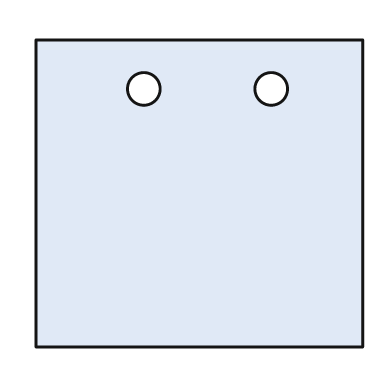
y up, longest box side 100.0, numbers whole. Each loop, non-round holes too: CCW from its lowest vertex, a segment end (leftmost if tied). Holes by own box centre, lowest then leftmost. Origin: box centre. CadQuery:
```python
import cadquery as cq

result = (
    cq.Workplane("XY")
    .moveTo(-50.0, -47.0)
    .lineTo(50.0, -47.0)
    .lineTo(50.0, 47.0)
    .lineTo(-50.0, 47.0)
    .close()
    .moveTo(-17.0, 32.0)
    .circle(5.0)
    .moveTo(22.0, 32.0)
    .circle(5.0)
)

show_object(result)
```